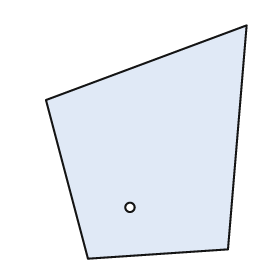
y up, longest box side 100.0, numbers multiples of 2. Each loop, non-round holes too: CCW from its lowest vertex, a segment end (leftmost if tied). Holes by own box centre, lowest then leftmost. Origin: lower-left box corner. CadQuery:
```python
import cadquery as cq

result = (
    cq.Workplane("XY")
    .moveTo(18.0, 0.0)
    .lineTo(78.0, 4.0)
    .lineTo(86.0, 100.0)
    .lineTo(0.0, 68.0)
    .close()
    .moveTo(36.0, 22.0)
    .circle(2.0)
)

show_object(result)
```